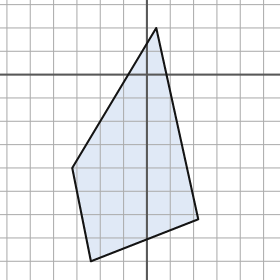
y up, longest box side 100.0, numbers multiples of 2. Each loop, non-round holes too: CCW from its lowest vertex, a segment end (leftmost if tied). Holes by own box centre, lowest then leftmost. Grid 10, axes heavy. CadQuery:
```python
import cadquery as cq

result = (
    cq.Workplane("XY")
    .moveTo(-24.0, -80.0)
    .lineTo(22.0, -62.0)
    .lineTo(4.0, 20.0)
    .lineTo(-32.0, -40.0)
    .close()
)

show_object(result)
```